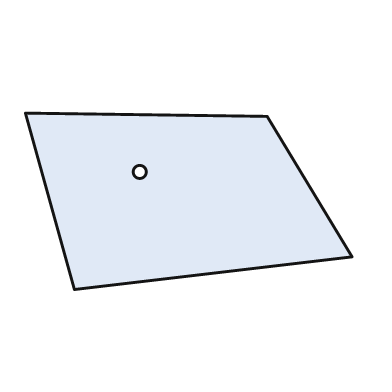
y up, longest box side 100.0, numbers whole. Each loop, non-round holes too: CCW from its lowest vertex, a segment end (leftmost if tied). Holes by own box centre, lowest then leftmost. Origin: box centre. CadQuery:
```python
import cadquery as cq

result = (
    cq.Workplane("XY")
    .moveTo(-35.0, -27.0)
    .lineTo(50.0, -17.0)
    .lineTo(24.0, 26.0)
    .lineTo(-50.0, 27.0)
    .close()
    .moveTo(-15.0, 9.0)
    .circle(2.0)
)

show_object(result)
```